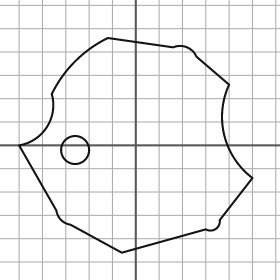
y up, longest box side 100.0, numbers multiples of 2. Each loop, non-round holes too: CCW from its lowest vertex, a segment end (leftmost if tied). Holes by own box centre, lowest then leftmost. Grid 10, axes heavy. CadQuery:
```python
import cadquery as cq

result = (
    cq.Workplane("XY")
    .moveTo(-6.0, -46.0)
    .lineTo(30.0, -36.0)
    .threePointArc((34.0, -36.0), (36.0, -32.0))
    .lineTo(50.0, -14.0)
    .threePointArc((38.0, 4.0), (40.0, 26.0))
    .lineTo(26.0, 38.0)
    .threePointArc((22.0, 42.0), (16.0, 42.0))
    .lineTo(-12.0, 46.0)
    .threePointArc((-26.0, 36.0), (-36.0, 22.0))
    .threePointArc((-38.0, 8.0), (-50.0, 0.0))
    .lineTo(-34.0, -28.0)
    .threePointArc((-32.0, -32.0), (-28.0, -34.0))
    .close()
    .moveTo(-26.0, -2.0)
    .circle(6.0)
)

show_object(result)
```